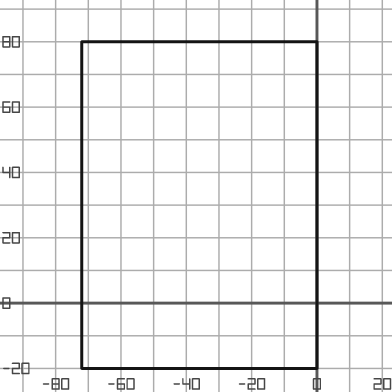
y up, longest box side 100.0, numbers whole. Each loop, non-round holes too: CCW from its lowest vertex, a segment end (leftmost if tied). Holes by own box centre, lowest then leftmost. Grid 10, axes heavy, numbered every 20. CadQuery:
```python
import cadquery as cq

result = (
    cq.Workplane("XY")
    .moveTo(-72.0, -20.0)
    .lineTo(0.0, -20.0)
    .lineTo(0.0, 80.0)
    .lineTo(-72.0, 80.0)
    .close()
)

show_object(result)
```